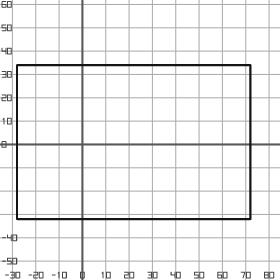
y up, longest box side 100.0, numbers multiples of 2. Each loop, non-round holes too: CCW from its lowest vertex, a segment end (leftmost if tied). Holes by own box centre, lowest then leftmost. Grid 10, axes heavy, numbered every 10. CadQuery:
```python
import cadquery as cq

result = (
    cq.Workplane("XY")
    .moveTo(-28.0, -32.0)
    .lineTo(72.0, -32.0)
    .lineTo(72.0, 34.0)
    .lineTo(-28.0, 34.0)
    .close()
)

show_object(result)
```